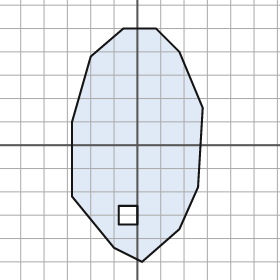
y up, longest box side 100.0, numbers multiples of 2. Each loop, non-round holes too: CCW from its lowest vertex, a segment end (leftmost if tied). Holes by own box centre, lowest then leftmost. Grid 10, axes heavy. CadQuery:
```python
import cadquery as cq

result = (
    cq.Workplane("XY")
    .moveTo(2.0, -50.0)
    .lineTo(18.0, -36.0)
    .lineTo(26.0, -18.0)
    .lineTo(28.0, 16.0)
    .lineTo(18.0, 40.0)
    .lineTo(8.0, 50.0)
    .lineTo(-6.0, 50.0)
    .lineTo(-20.0, 38.0)
    .lineTo(-28.0, 10.0)
    .lineTo(-28.0, -22.0)
    .lineTo(-10.0, -44.0)
    .close()
    .moveTo(-8.0, -34.0)
    .lineTo(0.0, -34.0)
    .lineTo(0.0, -26.0)
    .lineTo(-8.0, -26.0)
    .close()
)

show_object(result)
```